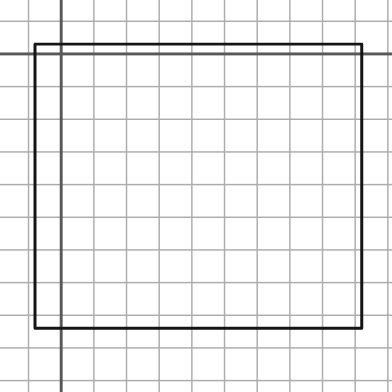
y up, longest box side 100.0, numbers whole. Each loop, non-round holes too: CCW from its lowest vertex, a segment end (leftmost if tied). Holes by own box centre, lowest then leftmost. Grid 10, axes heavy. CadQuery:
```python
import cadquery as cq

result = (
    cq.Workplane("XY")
    .moveTo(-8.0, -84.0)
    .lineTo(92.0, -84.0)
    .lineTo(92.0, 3.0)
    .lineTo(-8.0, 3.0)
    .close()
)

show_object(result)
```